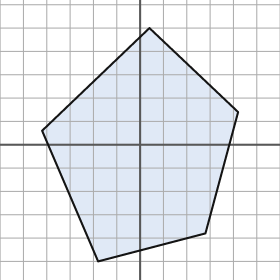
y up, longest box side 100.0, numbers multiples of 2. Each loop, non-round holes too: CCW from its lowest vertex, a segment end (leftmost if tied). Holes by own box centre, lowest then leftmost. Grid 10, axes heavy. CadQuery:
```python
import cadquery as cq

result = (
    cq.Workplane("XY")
    .moveTo(-18.0, -50.0)
    .lineTo(28.0, -38.0)
    .lineTo(42.0, 14.0)
    .lineTo(4.0, 50.0)
    .lineTo(-42.0, 6.0)
    .close()
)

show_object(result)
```